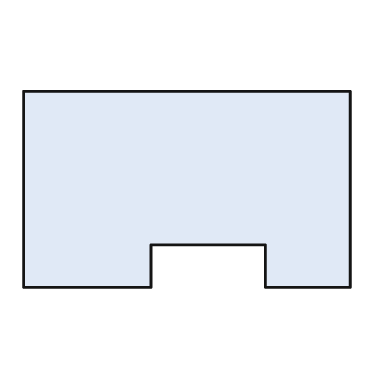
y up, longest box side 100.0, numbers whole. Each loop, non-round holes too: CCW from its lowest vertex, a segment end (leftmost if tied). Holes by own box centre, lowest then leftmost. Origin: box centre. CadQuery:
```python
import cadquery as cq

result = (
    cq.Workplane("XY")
    .moveTo(-50.0, -30.0)
    .lineTo(-11.0, -30.0)
    .lineTo(-11.0, -17.0)
    .lineTo(24.0, -17.0)
    .lineTo(24.0, -30.0)
    .lineTo(50.0, -30.0)
    .lineTo(50.0, 30.0)
    .lineTo(-50.0, 30.0)
    .close()
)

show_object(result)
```